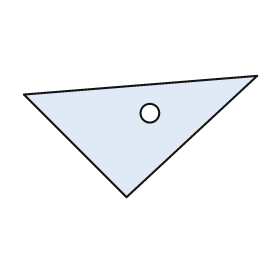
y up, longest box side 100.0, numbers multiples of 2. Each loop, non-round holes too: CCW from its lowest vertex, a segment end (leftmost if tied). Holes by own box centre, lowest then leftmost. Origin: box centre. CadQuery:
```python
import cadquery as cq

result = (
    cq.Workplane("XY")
    .moveTo(-6.0, -26.0)
    .lineTo(50.0, 26.0)
    .lineTo(-50.0, 18.0)
    .close()
    .moveTo(4.0, 10.0)
    .circle(4.0)
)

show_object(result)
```